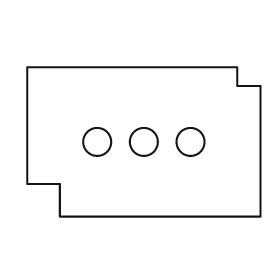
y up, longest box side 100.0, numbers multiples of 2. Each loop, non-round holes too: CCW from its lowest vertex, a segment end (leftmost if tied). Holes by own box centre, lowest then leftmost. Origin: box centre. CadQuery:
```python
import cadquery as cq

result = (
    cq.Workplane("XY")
    .moveTo(-36.0, -32.0)
    .lineTo(50.0, -32.0)
    .lineTo(50.0, 24.0)
    .lineTo(40.0, 24.0)
    .lineTo(40.0, 32.0)
    .lineTo(-50.0, 32.0)
    .lineTo(-50.0, -18.0)
    .lineTo(-36.0, -18.0)
    .close()
    .moveTo(-20.0, 0.0)
    .circle(6.0)
    .moveTo(0.0, 0.0)
    .circle(6.0)
    .moveTo(20.0, 0.0)
    .circle(6.0)
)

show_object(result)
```